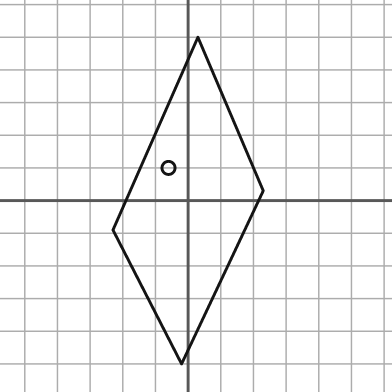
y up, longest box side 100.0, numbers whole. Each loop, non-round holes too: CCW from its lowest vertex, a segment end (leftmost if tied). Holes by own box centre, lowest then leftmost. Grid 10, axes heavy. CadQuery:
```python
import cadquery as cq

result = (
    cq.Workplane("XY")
    .moveTo(-2.0, -50.0)
    .lineTo(23.0, 3.0)
    .lineTo(3.0, 50.0)
    .lineTo(-23.0, -9.0)
    .close()
    .moveTo(-6.0, 10.0)
    .circle(2.0)
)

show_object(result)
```